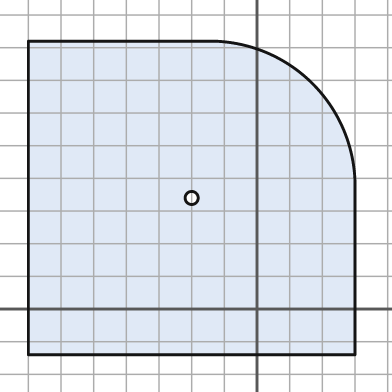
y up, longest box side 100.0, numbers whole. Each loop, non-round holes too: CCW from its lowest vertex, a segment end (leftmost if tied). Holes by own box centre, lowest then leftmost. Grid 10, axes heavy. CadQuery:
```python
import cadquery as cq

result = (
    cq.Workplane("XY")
    .moveTo(-70.0, -14.0)
    .lineTo(30.0, -14.0)
    .lineTo(30.0, 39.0)
    .threePointArc((17.0, 69.0), (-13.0, 82.0))
    .lineTo(-70.0, 82.0)
    .close()
    .moveTo(-20.0, 34.0)
    .circle(2.0)
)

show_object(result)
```